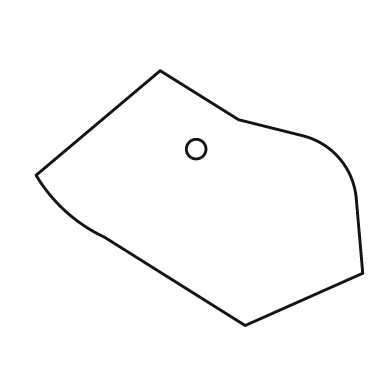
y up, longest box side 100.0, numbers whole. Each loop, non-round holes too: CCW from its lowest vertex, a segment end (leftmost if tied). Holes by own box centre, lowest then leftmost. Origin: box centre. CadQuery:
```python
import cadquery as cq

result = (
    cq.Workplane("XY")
    .moveTo(14.0, -39.0)
    .lineTo(50.0, -23.0)
    .lineTo(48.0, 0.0)
    .threePointArc((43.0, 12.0), (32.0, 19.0))
    .lineTo(12.0, 24.0)
    .lineTo(-12.0, 39.0)
    .lineTo(-50.0, 7.0)
    .threePointArc((-41.0, -4.0), (-29.0, -12.0))
    .close()
    .moveTo(-1.0, 15.0)
    .circle(3.0)
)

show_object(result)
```